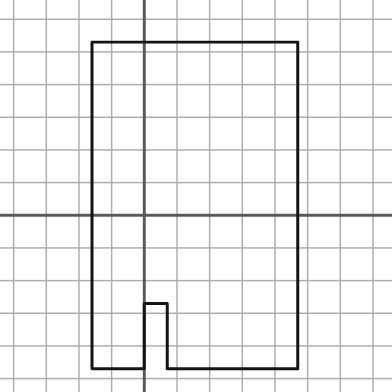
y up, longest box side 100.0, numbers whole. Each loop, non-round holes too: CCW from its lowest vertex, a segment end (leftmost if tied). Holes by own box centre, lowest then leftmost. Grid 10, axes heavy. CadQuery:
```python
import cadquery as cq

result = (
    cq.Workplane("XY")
    .moveTo(-16.0, -47.0)
    .lineTo(0.0, -47.0)
    .lineTo(0.0, -27.0)
    .lineTo(7.0, -27.0)
    .lineTo(7.0, -47.0)
    .lineTo(47.0, -47.0)
    .lineTo(47.0, 53.0)
    .lineTo(-16.0, 53.0)
    .close()
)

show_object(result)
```